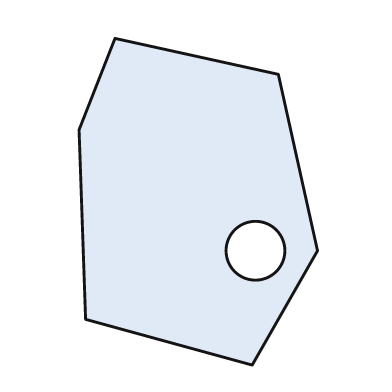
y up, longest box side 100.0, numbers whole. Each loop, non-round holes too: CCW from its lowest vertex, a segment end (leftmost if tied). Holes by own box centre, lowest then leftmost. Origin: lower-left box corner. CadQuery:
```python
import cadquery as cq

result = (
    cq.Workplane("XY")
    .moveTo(53.0, 0.0)
    .lineTo(73.0, 35.0)
    .lineTo(61.0, 89.0)
    .lineTo(11.0, 100.0)
    .lineTo(0.0, 72.0)
    .lineTo(2.0, 14.0)
    .close()
    .moveTo(54.0, 35.0)
    .circle(9.0)
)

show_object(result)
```